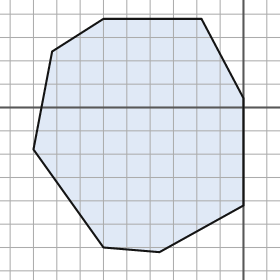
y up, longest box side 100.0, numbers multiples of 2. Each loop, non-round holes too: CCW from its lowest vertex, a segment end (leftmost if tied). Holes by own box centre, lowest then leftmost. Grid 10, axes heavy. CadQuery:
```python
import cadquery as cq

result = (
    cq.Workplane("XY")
    .moveTo(-36.0, -62.0)
    .lineTo(0.0, -42.0)
    .lineTo(0.0, 4.0)
    .lineTo(-18.0, 38.0)
    .lineTo(-60.0, 38.0)
    .lineTo(-82.0, 24.0)
    .lineTo(-90.0, -18.0)
    .lineTo(-60.0, -60.0)
    .close()
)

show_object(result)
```